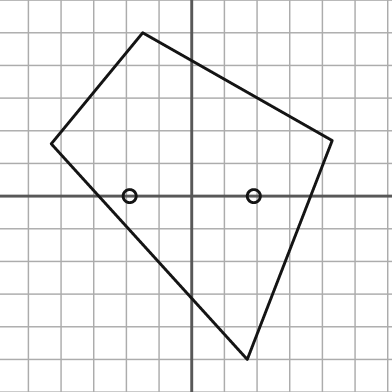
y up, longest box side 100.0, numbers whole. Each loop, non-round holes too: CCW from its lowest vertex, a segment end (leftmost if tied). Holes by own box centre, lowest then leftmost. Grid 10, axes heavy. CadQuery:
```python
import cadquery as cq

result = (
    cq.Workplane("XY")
    .moveTo(17.0, -50.0)
    .lineTo(43.0, 17.0)
    .lineTo(-15.0, 50.0)
    .lineTo(-43.0, 16.0)
    .close()
    .moveTo(-19.0, 0.0)
    .circle(2.0)
    .moveTo(19.0, 0.0)
    .circle(2.0)
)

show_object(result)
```